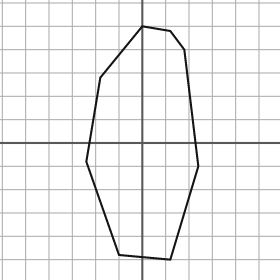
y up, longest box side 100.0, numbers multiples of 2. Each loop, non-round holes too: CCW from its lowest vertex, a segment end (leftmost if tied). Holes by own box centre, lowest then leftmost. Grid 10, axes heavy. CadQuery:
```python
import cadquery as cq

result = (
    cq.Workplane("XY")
    .moveTo(12.0, -50.0)
    .lineTo(24.0, -10.0)
    .lineTo(18.0, 40.0)
    .lineTo(12.0, 48.0)
    .lineTo(0.0, 50.0)
    .lineTo(-18.0, 28.0)
    .lineTo(-24.0, -8.0)
    .lineTo(-10.0, -48.0)
    .close()
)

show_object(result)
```